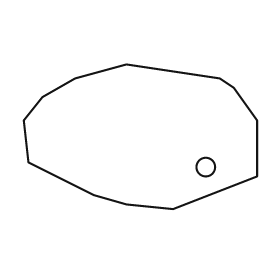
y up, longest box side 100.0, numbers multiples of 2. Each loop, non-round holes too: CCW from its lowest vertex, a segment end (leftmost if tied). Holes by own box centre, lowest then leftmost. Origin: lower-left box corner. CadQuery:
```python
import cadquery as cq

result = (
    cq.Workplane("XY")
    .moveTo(64.0, 0.0)
    .lineTo(100.0, 14.0)
    .lineTo(100.0, 38.0)
    .lineTo(90.0, 52.0)
    .lineTo(84.0, 56.0)
    .lineTo(44.0, 62.0)
    .lineTo(22.0, 56.0)
    .lineTo(8.0, 48.0)
    .lineTo(0.0, 38.0)
    .lineTo(2.0, 20.0)
    .lineTo(30.0, 6.0)
    .lineTo(44.0, 2.0)
    .close()
    .moveTo(78.0, 18.0)
    .circle(4.0)
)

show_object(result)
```